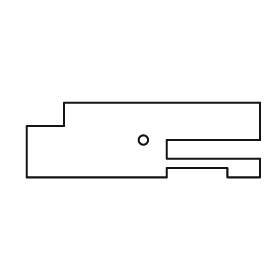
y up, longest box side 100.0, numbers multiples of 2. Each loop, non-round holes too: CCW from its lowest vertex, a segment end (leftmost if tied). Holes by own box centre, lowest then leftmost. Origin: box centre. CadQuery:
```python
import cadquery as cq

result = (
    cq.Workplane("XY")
    .moveTo(-50.0, -16.0)
    .lineTo(10.0, -16.0)
    .lineTo(10.0, -12.0)
    .lineTo(36.0, -12.0)
    .lineTo(36.0, -16.0)
    .lineTo(50.0, -16.0)
    .lineTo(50.0, -8.0)
    .lineTo(10.0, -8.0)
    .lineTo(10.0, 0.0)
    .lineTo(50.0, 0.0)
    .lineTo(50.0, 16.0)
    .lineTo(-34.0, 16.0)
    .lineTo(-34.0, 6.0)
    .lineTo(-50.0, 6.0)
    .close()
    .moveTo(0.0, 0.0)
    .circle(2.0)
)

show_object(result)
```